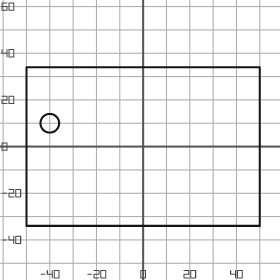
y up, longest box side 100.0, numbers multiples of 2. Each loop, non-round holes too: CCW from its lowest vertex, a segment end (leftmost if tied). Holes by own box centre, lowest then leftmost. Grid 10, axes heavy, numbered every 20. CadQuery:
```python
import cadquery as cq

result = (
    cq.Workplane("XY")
    .moveTo(-50.0, -34.0)
    .lineTo(50.0, -34.0)
    .lineTo(50.0, 34.0)
    .lineTo(-50.0, 34.0)
    .close()
    .moveTo(-40.0, 10.0)
    .circle(4.0)
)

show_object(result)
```